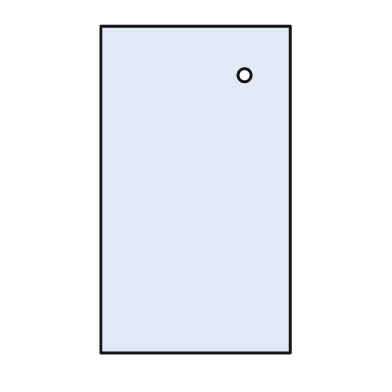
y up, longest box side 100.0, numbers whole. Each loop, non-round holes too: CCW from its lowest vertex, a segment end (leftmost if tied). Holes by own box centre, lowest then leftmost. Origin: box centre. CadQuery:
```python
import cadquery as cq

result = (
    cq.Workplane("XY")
    .moveTo(-29.0, -50.0)
    .lineTo(29.0, -50.0)
    .lineTo(29.0, 50.0)
    .lineTo(-29.0, 50.0)
    .close()
    .moveTo(15.0, 35.0)
    .circle(2.0)
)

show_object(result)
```